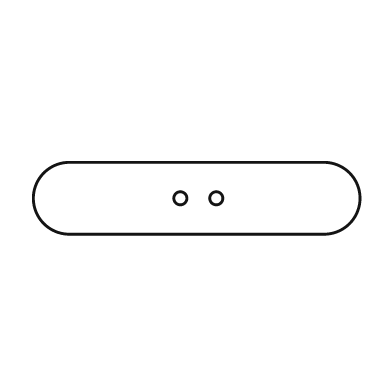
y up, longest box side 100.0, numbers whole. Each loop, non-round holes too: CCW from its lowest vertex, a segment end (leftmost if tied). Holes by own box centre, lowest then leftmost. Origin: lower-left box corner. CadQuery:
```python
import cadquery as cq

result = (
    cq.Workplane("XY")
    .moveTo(11.0, 0.0)
    .lineTo(89.0, 0.0)
    .threePointArc((100.0, 11.0), (89.0, 22.0))
    .lineTo(11.0, 22.0)
    .threePointArc((0.0, 11.0), (11.0, 0.0))
    .close()
    .moveTo(45.0, 11.0)
    .circle(2.0)
    .moveTo(56.0, 11.0)
    .circle(2.0)
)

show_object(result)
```